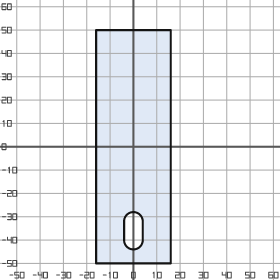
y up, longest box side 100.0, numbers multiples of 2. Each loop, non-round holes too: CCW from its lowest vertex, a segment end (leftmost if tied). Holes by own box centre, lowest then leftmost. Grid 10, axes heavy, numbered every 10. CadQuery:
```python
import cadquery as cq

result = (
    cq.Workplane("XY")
    .moveTo(-16.0, -50.0)
    .lineTo(16.0, -50.0)
    .lineTo(16.0, 50.0)
    .lineTo(-16.0, 50.0)
    .close()
    .moveTo(-4.0, -40.0)
    .threePointArc((0.0, -44.0), (4.0, -40.0))
    .lineTo(4.0, -32.0)
    .threePointArc((0.0, -28.0), (-4.0, -32.0))
    .close()
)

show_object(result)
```